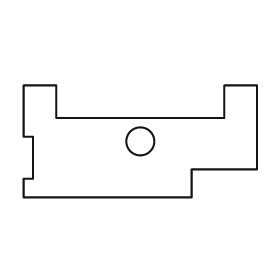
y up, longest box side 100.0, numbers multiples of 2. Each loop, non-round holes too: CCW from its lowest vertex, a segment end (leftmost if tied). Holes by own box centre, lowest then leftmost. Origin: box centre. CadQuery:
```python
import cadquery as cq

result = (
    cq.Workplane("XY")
    .moveTo(-50.0, -24.0)
    .lineTo(22.0, -24.0)
    .lineTo(22.0, -12.0)
    .lineTo(50.0, -12.0)
    .lineTo(50.0, 24.0)
    .lineTo(36.0, 24.0)
    .lineTo(36.0, 10.0)
    .lineTo(-36.0, 10.0)
    .lineTo(-36.0, 24.0)
    .lineTo(-50.0, 24.0)
    .lineTo(-50.0, 2.0)
    .lineTo(-46.0, 2.0)
    .lineTo(-46.0, -16.0)
    .lineTo(-50.0, -16.0)
    .close()
    .moveTo(0.0, 0.0)
    .circle(6.0)
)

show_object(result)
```